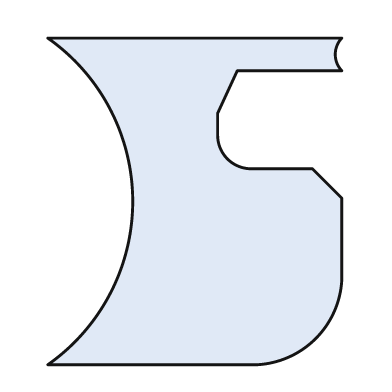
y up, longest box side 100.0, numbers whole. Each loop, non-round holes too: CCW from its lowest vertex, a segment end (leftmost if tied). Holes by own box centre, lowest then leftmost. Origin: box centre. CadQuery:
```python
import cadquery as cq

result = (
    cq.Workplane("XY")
    .moveTo(-45.0, -50.0)
    .lineTo(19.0, -50.0)
    .threePointArc((37.0, -42.0), (45.0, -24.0))
    .lineTo(45.0, 1.0)
    .lineTo(36.0, 10.0)
    .lineTo(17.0, 10.0)
    .threePointArc((10.0, 13.0), (7.0, 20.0))
    .lineTo(7.0, 27.0)
    .lineTo(13.0, 40.0)
    .lineTo(45.0, 40.0)
    .threePointArc((43.0, 45.0), (45.0, 50.0))
    .lineTo(-45.0, 50.0)
    .threePointArc((-19.0, 0.0), (-45.0, -50.0))
    .close()
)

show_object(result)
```